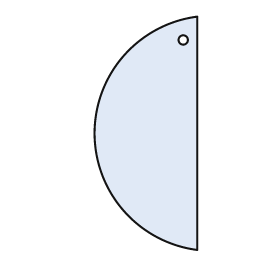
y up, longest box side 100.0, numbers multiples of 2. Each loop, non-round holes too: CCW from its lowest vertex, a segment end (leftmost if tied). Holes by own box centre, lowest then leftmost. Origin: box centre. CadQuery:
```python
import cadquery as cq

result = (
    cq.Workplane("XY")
    .moveTo(22.0, -50.0)
    .lineTo(22.0, 50.0)
    .threePointArc((-22.0, 0.0), (22.0, -50.0))
    .close()
    .moveTo(16.0, 40.0)
    .circle(2.0)
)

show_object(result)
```